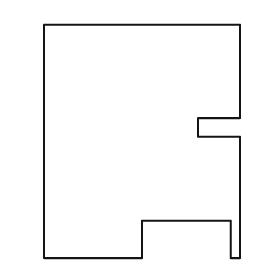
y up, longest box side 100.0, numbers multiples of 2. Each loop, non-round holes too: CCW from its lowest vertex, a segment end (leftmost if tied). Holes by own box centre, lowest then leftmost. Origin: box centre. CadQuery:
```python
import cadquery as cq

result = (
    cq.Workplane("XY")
    .moveTo(-42.0, -50.0)
    .lineTo(0.0, -50.0)
    .lineTo(0.0, -34.0)
    .lineTo(38.0, -34.0)
    .lineTo(38.0, -50.0)
    .lineTo(42.0, -50.0)
    .lineTo(42.0, 2.0)
    .lineTo(24.0, 2.0)
    .lineTo(24.0, 10.0)
    .lineTo(42.0, 10.0)
    .lineTo(42.0, 50.0)
    .lineTo(-42.0, 50.0)
    .close()
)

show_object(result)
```